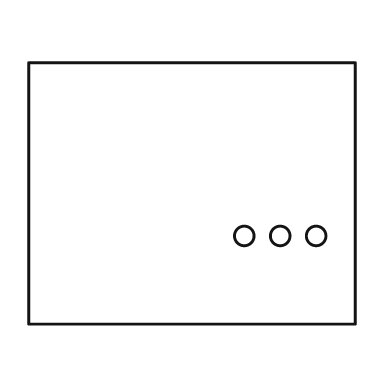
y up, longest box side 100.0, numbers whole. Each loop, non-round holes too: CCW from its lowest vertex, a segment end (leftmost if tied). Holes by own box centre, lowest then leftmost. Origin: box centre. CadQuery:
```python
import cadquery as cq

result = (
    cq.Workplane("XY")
    .moveTo(-50.0, -40.0)
    .lineTo(50.0, -40.0)
    .lineTo(50.0, 40.0)
    .lineTo(-50.0, 40.0)
    .close()
    .moveTo(16.0, -13.0)
    .circle(3.0)
    .moveTo(27.0, -13.0)
    .circle(3.0)
    .moveTo(38.0, -13.0)
    .circle(3.0)
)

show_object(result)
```